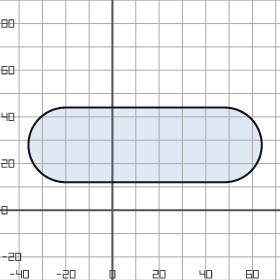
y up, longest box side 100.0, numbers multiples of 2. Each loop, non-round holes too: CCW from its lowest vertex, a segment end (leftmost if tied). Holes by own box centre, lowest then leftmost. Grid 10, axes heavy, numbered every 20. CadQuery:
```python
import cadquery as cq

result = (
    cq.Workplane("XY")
    .moveTo(-20.0, 12.0)
    .lineTo(48.0, 12.0)
    .threePointArc((64.0, 28.0), (48.0, 44.0))
    .lineTo(-20.0, 44.0)
    .threePointArc((-36.0, 28.0), (-20.0, 12.0))
    .close()
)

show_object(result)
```